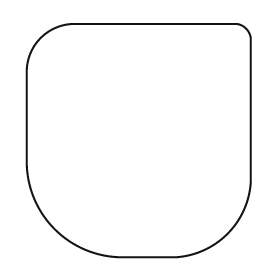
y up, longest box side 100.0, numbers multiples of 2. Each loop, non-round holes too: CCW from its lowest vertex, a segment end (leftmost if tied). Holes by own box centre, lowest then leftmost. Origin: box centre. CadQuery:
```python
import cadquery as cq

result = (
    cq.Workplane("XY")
    .moveTo(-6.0, -50.0)
    .lineTo(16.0, -50.0)
    .threePointArc((38.0, -40.0), (48.0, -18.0))
    .lineTo(48.0, 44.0)
    .threePointArc((46.0, 48.0), (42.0, 50.0))
    .lineTo(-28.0, 50.0)
    .threePointArc((-42.0, 44.0), (-48.0, 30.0))
    .lineTo(-48.0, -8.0)
    .threePointArc((-36.0, -38.0), (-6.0, -50.0))
    .close()
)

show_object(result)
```